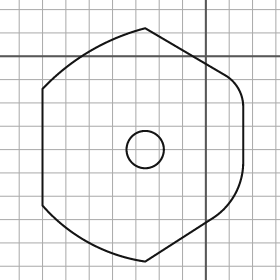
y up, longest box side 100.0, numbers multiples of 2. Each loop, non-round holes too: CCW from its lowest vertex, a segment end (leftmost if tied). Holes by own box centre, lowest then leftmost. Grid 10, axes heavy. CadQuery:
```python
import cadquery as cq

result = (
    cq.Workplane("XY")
    .moveTo(-26.0, -88.0)
    .lineTo(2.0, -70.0)
    .threePointArc((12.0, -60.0), (16.0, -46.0))
    .lineTo(16.0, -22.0)
    .threePointArc((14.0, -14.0), (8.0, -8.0))
    .lineTo(-26.0, 12.0)
    .threePointArc((-50.0, 2.0), (-70.0, -14.0))
    .lineTo(-70.0, -64.0)
    .threePointArc((-50.0, -80.0), (-26.0, -88.0))
    .close()
    .moveTo(-26.0, -40.0)
    .circle(8.0)
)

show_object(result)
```